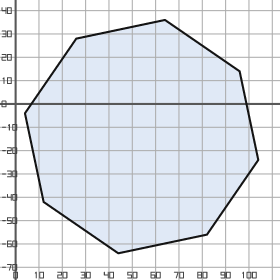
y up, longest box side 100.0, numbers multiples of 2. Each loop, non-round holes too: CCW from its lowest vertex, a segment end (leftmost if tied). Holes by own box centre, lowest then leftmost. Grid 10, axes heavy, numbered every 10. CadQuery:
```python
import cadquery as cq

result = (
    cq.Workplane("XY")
    .moveTo(44.0, -64.0)
    .lineTo(82.0, -56.0)
    .lineTo(104.0, -24.0)
    .lineTo(96.0, 14.0)
    .lineTo(64.0, 36.0)
    .lineTo(26.0, 28.0)
    .lineTo(4.0, -4.0)
    .lineTo(12.0, -42.0)
    .close()
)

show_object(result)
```